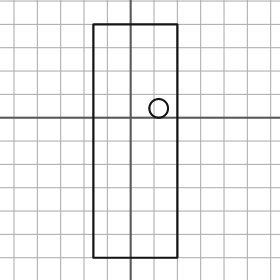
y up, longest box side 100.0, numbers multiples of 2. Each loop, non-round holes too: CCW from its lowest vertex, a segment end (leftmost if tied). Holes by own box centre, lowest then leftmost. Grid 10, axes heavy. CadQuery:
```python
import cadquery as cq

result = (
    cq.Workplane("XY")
    .moveTo(-16.0, -60.0)
    .lineTo(20.0, -60.0)
    .lineTo(20.0, 40.0)
    .lineTo(-16.0, 40.0)
    .close()
    .moveTo(12.0, 4.0)
    .circle(4.0)
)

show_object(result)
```